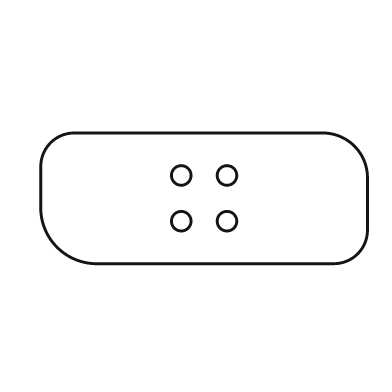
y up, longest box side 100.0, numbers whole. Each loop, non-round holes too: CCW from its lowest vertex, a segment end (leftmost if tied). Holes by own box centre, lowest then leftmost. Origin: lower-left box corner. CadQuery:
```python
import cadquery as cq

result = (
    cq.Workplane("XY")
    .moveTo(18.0, 0.0)
    .lineTo(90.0, 0.0)
    .threePointArc((97.0, 3.0), (100.0, 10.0))
    .lineTo(100.0, 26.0)
    .threePointArc((96.0, 36.0), (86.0, 40.0))
    .lineTo(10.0, 40.0)
    .threePointArc((3.0, 37.0), (0.0, 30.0))
    .lineTo(0.0, 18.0)
    .threePointArc((5.0, 5.0), (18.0, 0.0))
    .close()
    .moveTo(43.0, 13.0)
    .circle(3.0)
    .moveTo(57.0, 13.0)
    .circle(3.0)
    .moveTo(43.0, 27.0)
    .circle(3.0)
    .moveTo(57.0, 27.0)
    .circle(3.0)
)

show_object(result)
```